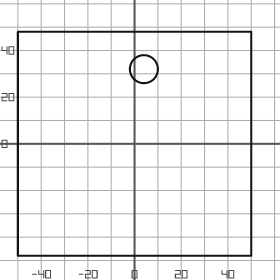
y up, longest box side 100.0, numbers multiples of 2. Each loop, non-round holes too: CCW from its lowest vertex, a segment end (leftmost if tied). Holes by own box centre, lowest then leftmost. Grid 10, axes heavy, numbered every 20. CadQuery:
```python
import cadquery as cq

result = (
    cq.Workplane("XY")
    .moveTo(-50.0, -48.0)
    .lineTo(50.0, -48.0)
    .lineTo(50.0, 48.0)
    .lineTo(-50.0, 48.0)
    .close()
    .moveTo(4.0, 32.0)
    .circle(6.0)
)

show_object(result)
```